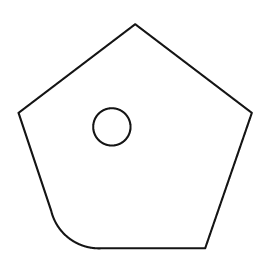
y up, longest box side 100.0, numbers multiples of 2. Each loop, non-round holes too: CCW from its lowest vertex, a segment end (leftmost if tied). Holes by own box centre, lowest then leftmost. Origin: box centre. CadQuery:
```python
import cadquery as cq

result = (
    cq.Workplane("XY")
    .moveTo(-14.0, -48.0)
    .lineTo(30.0, -48.0)
    .lineTo(50.0, 10.0)
    .lineTo(0.0, 48.0)
    .lineTo(-50.0, 10.0)
    .lineTo(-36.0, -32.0)
    .threePointArc((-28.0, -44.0), (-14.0, -48.0))
    .close()
    .moveTo(-10.0, 4.0)
    .circle(8.0)
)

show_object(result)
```